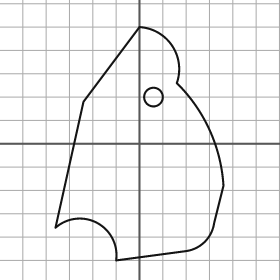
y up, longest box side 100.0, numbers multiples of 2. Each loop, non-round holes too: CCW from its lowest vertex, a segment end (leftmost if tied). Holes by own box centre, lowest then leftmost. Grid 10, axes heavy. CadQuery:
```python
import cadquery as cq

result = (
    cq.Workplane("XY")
    .moveTo(-10.0, -50.0)
    .lineTo(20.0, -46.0)
    .threePointArc((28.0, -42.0), (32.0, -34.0))
    .lineTo(36.0, -18.0)
    .threePointArc((30.0, 6.0), (16.0, 26.0))
    .threePointArc((14.0, 42.0), (0.0, 50.0))
    .lineTo(-24.0, 18.0)
    .lineTo(-36.0, -36.0)
    .threePointArc((-18.0, -34.0), (-10.0, -50.0))
    .close()
    .moveTo(6.0, 20.0)
    .circle(4.0)
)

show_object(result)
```